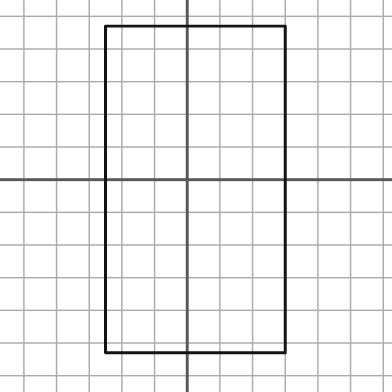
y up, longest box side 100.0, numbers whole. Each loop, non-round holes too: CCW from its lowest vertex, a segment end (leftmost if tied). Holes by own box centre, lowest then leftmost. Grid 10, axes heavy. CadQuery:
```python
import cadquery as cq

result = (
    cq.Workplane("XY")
    .moveTo(-25.0, -53.0)
    .lineTo(30.0, -53.0)
    .lineTo(30.0, 47.0)
    .lineTo(-25.0, 47.0)
    .close()
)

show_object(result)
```